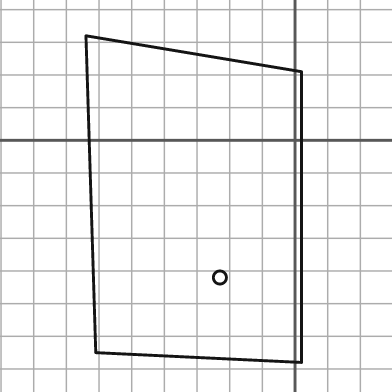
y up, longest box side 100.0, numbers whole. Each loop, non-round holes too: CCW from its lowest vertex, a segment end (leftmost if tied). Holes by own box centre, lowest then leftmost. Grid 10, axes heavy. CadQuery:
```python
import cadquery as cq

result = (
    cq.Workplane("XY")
    .moveTo(2.0, -68.0)
    .lineTo(2.0, 21.0)
    .lineTo(-64.0, 32.0)
    .lineTo(-61.0, -65.0)
    .close()
    .moveTo(-23.0, -42.0)
    .circle(2.0)
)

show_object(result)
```